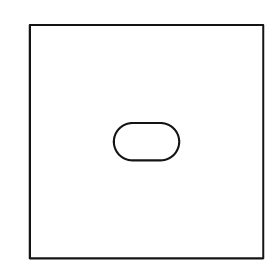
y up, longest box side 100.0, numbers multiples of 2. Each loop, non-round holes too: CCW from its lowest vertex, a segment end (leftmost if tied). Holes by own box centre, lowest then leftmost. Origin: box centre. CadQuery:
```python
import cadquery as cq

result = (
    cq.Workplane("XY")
    .moveTo(-50.0, -50.0)
    .lineTo(50.0, -50.0)
    .lineTo(50.0, 50.0)
    .lineTo(-50.0, 50.0)
    .close()
    .moveTo(-6.0, -8.0)
    .lineTo(6.0, -8.0)
    .threePointArc((14.0, 0.0), (6.0, 8.0))
    .lineTo(-6.0, 8.0)
    .threePointArc((-14.0, 0.0), (-6.0, -8.0))
    .close()
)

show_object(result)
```